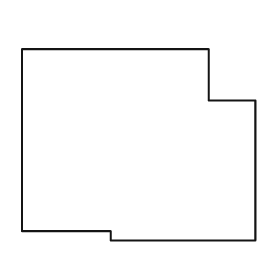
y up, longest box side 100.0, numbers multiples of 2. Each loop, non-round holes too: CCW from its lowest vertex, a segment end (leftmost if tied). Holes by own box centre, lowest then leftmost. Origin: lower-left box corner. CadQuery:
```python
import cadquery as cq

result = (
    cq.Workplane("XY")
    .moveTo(38.0, 0.0)
    .lineTo(100.0, 0.0)
    .lineTo(100.0, 60.0)
    .lineTo(80.0, 60.0)
    .lineTo(80.0, 82.0)
    .lineTo(0.0, 82.0)
    .lineTo(0.0, 4.0)
    .lineTo(38.0, 4.0)
    .close()
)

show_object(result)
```